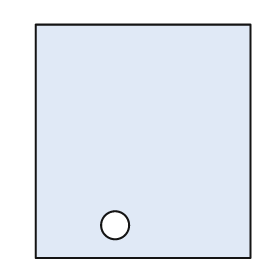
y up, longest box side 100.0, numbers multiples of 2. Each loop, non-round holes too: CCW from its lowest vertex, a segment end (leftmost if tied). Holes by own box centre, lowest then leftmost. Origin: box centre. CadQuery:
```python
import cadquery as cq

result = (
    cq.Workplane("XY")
    .moveTo(-46.0, -50.0)
    .lineTo(46.0, -50.0)
    .lineTo(46.0, 50.0)
    .lineTo(-46.0, 50.0)
    .close()
    .moveTo(-12.0, -36.0)
    .circle(6.0)
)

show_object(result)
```